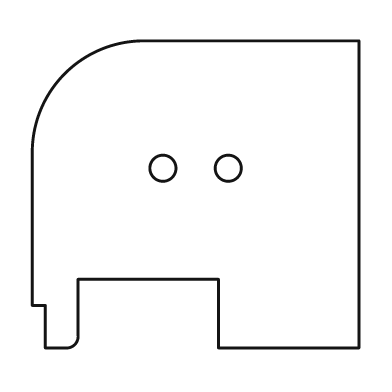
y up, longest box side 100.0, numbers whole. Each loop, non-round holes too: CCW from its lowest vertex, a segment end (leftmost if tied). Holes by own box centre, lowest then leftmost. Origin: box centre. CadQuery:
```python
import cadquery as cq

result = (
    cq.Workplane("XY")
    .moveTo(-46.0, -47.0)
    .lineTo(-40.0, -47.0)
    .threePointArc((-37.0, -46.0), (-36.0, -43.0))
    .lineTo(-36.0, -26.0)
    .lineTo(7.0, -26.0)
    .lineTo(7.0, -47.0)
    .lineTo(50.0, -47.0)
    .lineTo(50.0, 47.0)
    .lineTo(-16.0, 47.0)
    .threePointArc((-40.0, 37.0), (-50.0, 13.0))
    .lineTo(-50.0, -34.0)
    .lineTo(-46.0, -34.0)
    .close()
    .moveTo(-10.0, 8.0)
    .circle(4.0)
    .moveTo(10.0, 8.0)
    .circle(4.0)
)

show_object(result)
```